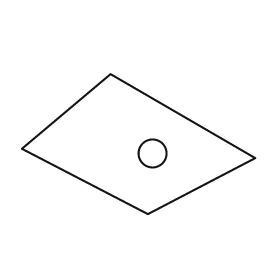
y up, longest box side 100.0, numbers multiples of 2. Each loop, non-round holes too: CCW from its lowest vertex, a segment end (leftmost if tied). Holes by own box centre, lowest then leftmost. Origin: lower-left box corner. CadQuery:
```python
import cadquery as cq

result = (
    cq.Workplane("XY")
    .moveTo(54.0, 0.0)
    .lineTo(100.0, 24.0)
    .lineTo(38.0, 60.0)
    .lineTo(0.0, 28.0)
    .close()
    .moveTo(56.0, 26.0)
    .circle(6.0)
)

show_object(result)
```